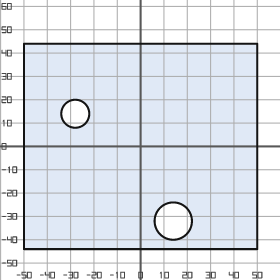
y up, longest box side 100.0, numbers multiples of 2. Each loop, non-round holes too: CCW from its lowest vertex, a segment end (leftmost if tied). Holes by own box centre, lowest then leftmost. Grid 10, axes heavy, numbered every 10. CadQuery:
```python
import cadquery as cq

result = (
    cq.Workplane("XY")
    .moveTo(-50.0, -44.0)
    .lineTo(50.0, -44.0)
    .lineTo(50.0, 44.0)
    .lineTo(-50.0, 44.0)
    .close()
    .moveTo(14.0, -32.0)
    .circle(8.0)
    .moveTo(-28.0, 14.0)
    .circle(6.0)
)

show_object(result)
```